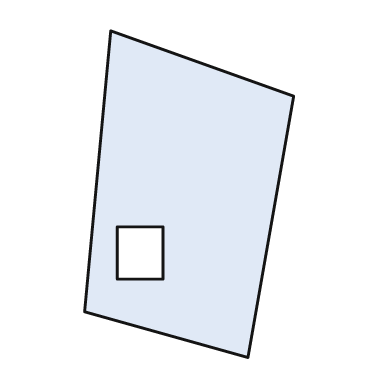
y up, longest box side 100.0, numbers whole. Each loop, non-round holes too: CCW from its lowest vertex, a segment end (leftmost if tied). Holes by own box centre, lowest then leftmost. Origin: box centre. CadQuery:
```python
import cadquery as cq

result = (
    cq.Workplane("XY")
    .moveTo(18.0, -50.0)
    .lineTo(32.0, 30.0)
    .lineTo(-24.0, 50.0)
    .lineTo(-32.0, -36.0)
    .close()
    .moveTo(-22.0, -26.0)
    .lineTo(-8.0, -26.0)
    .lineTo(-8.0, -10.0)
    .lineTo(-22.0, -10.0)
    .close()
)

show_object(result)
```